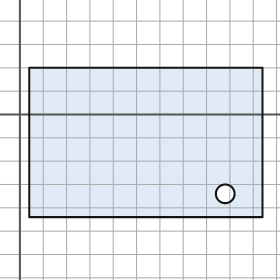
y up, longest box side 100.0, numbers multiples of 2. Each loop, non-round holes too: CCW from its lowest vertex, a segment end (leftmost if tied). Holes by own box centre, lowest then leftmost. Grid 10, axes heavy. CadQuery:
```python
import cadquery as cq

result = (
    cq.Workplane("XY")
    .moveTo(4.0, -44.0)
    .lineTo(104.0, -44.0)
    .lineTo(104.0, 20.0)
    .lineTo(4.0, 20.0)
    .close()
    .moveTo(88.0, -34.0)
    .circle(4.0)
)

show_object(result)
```